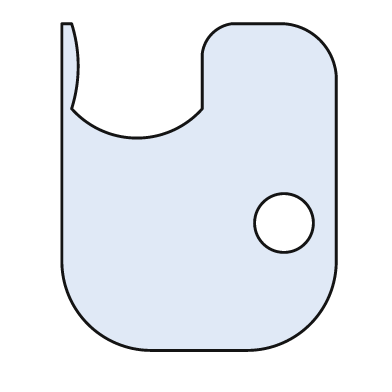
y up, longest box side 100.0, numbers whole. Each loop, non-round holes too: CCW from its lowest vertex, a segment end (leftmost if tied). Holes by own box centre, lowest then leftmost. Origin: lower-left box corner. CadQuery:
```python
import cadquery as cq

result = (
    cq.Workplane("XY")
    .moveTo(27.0, 0.0)
    .lineTo(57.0, 0.0)
    .threePointArc((76.0, 8.0), (84.0, 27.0))
    .lineTo(84.0, 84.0)
    .threePointArc((79.0, 95.0), (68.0, 100.0))
    .lineTo(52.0, 100.0)
    .threePointArc((46.0, 97.0), (43.0, 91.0))
    .lineTo(43.0, 74.0)
    .threePointArc((23.0, 65.0), (3.0, 74.0))
    .threePointArc((5.0, 87.0), (3.0, 100.0))
    .lineTo(0.0, 100.0)
    .lineTo(0.0, 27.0)
    .threePointArc((8.0, 8.0), (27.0, 0.0))
    .close()
    .moveTo(68.0, 39.0)
    .circle(9.0)
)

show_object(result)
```